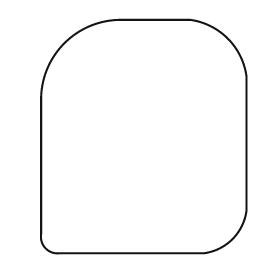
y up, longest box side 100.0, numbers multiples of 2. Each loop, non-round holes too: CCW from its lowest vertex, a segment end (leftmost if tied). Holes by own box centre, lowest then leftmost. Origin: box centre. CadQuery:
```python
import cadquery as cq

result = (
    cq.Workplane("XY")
    .moveTo(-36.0, -50.0)
    .lineTo(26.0, -50.0)
    .threePointArc((38.0, -44.0), (44.0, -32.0))
    .lineTo(44.0, 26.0)
    .threePointArc((36.0, 42.0), (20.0, 50.0))
    .lineTo(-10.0, 50.0)
    .threePointArc((-34.0, 40.0), (-44.0, 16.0))
    .lineTo(-44.0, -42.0)
    .threePointArc((-42.0, -48.0), (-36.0, -50.0))
    .close()
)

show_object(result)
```